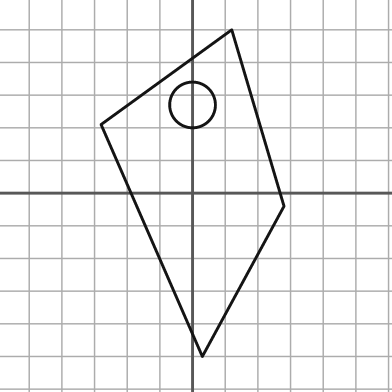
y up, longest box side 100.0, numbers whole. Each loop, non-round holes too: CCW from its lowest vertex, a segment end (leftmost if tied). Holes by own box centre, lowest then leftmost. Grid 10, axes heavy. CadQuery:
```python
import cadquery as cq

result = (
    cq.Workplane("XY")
    .moveTo(3.0, -50.0)
    .lineTo(28.0, -4.0)
    .lineTo(12.0, 50.0)
    .lineTo(-28.0, 21.0)
    .close()
    .moveTo(0.0, 27.0)
    .circle(7.0)
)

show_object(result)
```